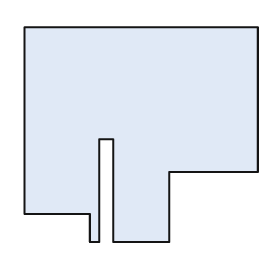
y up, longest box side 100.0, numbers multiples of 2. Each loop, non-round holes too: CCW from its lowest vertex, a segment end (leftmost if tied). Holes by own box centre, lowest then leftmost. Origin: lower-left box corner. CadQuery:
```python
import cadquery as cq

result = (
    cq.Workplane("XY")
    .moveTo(28.0, 0.0)
    .lineTo(32.0, 0.0)
    .lineTo(32.0, 44.0)
    .lineTo(38.0, 44.0)
    .lineTo(38.0, 0.0)
    .lineTo(62.0, 0.0)
    .lineTo(62.0, 30.0)
    .lineTo(100.0, 30.0)
    .lineTo(100.0, 92.0)
    .lineTo(0.0, 92.0)
    .lineTo(0.0, 12.0)
    .lineTo(28.0, 12.0)
    .close()
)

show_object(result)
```